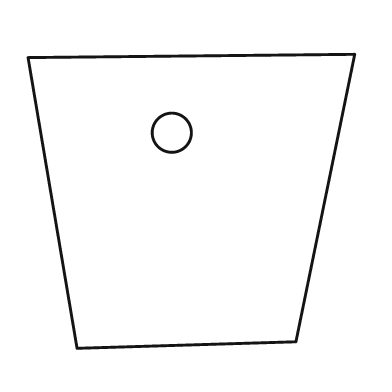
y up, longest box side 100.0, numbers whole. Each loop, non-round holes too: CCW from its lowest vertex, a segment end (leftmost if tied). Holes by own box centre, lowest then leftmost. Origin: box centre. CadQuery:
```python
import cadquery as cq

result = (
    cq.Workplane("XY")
    .moveTo(-35.0, -45.0)
    .lineTo(32.0, -43.0)
    .lineTo(50.0, 45.0)
    .lineTo(-50.0, 44.0)
    .close()
    .moveTo(-6.0, 21.0)
    .circle(6.0)
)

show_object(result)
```